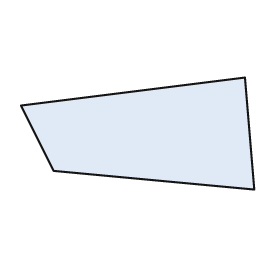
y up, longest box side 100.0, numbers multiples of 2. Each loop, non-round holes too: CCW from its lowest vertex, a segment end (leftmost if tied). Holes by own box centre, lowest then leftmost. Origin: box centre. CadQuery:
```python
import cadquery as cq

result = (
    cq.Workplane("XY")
    .moveTo(50.0, -24.0)
    .lineTo(46.0, 24.0)
    .lineTo(-50.0, 12.0)
    .lineTo(-36.0, -16.0)
    .close()
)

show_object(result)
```